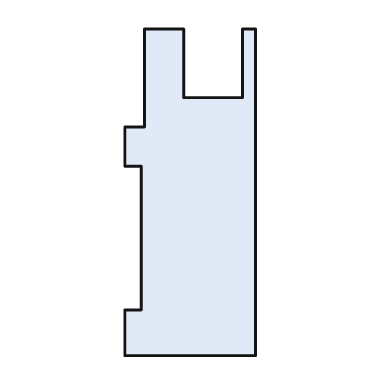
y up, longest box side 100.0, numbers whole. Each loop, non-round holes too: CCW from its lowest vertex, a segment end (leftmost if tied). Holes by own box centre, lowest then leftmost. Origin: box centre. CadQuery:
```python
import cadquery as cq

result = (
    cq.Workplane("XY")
    .moveTo(-20.0, -50.0)
    .lineTo(20.0, -50.0)
    .lineTo(20.0, 50.0)
    .lineTo(16.0, 50.0)
    .lineTo(16.0, 29.0)
    .lineTo(-2.0, 29.0)
    .lineTo(-2.0, 50.0)
    .lineTo(-14.0, 50.0)
    .lineTo(-14.0, 20.0)
    .lineTo(-20.0, 20.0)
    .lineTo(-20.0, 8.0)
    .lineTo(-15.0, 8.0)
    .lineTo(-15.0, -36.0)
    .lineTo(-20.0, -36.0)
    .close()
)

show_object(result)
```